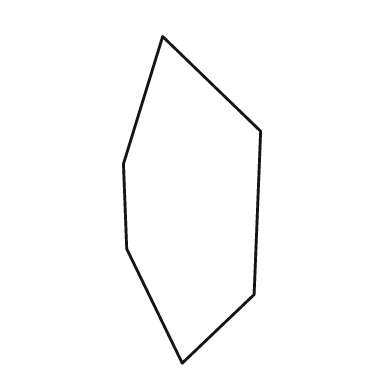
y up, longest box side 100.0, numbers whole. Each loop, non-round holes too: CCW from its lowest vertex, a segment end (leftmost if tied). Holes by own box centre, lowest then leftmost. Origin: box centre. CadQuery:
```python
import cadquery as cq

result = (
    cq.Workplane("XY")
    .moveTo(-3.0, -50.0)
    .lineTo(19.0, -29.0)
    .lineTo(21.0, 21.0)
    .lineTo(-9.0, 50.0)
    .lineTo(-21.0, 11.0)
    .lineTo(-20.0, -15.0)
    .close()
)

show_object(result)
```